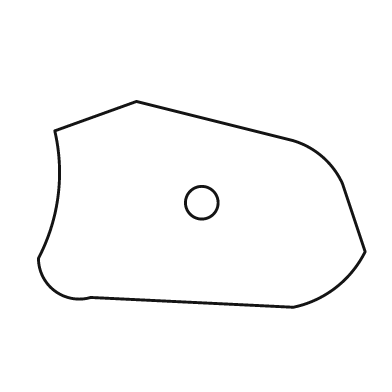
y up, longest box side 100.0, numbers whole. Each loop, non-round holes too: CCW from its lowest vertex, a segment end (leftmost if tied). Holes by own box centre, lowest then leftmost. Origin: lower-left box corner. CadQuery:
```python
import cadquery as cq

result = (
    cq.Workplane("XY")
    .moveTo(78.0, 0.0)
    .threePointArc((91.0, 6.0), (100.0, 17.0))
    .lineTo(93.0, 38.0)
    .threePointArc((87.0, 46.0), (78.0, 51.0))
    .lineTo(30.0, 63.0)
    .lineTo(5.0, 54.0)
    .threePointArc((6.0, 34.0), (0.0, 15.0))
    .threePointArc((5.0, 5.0), (16.0, 3.0))
    .close()
    .moveTo(50.0, 32.0)
    .circle(5.0)
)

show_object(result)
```